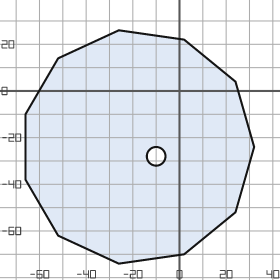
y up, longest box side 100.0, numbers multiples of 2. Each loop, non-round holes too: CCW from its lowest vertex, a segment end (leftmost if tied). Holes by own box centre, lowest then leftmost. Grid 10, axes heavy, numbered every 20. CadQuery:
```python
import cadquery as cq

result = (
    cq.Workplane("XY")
    .moveTo(-26.0, -74.0)
    .lineTo(2.0, -70.0)
    .lineTo(24.0, -52.0)
    .lineTo(32.0, -24.0)
    .lineTo(24.0, 4.0)
    .lineTo(2.0, 22.0)
    .lineTo(-26.0, 26.0)
    .lineTo(-52.0, 14.0)
    .lineTo(-66.0, -10.0)
    .lineTo(-66.0, -38.0)
    .lineTo(-52.0, -62.0)
    .close()
    .moveTo(-10.0, -28.0)
    .circle(4.0)
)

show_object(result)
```